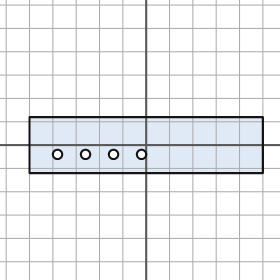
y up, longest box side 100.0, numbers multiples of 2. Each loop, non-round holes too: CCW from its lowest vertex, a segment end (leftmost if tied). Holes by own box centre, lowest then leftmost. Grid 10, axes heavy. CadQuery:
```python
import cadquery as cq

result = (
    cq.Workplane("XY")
    .moveTo(-50.0, -12.0)
    .lineTo(50.0, -12.0)
    .lineTo(50.0, 12.0)
    .lineTo(-50.0, 12.0)
    .close()
    .moveTo(-38.0, -4.0)
    .circle(2.0)
    .moveTo(-26.0, -4.0)
    .circle(2.0)
    .moveTo(-14.0, -4.0)
    .circle(2.0)
    .moveTo(-2.0, -4.0)
    .circle(2.0)
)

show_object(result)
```